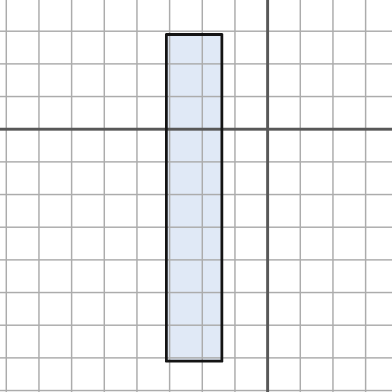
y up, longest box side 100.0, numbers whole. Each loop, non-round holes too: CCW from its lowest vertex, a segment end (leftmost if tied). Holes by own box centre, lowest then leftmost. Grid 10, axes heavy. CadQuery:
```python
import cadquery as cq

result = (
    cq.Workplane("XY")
    .moveTo(-31.0, -71.0)
    .lineTo(-14.0, -71.0)
    .lineTo(-14.0, 29.0)
    .lineTo(-31.0, 29.0)
    .close()
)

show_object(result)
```